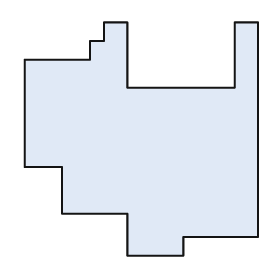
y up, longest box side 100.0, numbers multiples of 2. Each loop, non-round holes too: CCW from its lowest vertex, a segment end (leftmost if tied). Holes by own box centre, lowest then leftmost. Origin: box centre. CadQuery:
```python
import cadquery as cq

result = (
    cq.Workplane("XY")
    .moveTo(-6.0, -50.0)
    .lineTo(18.0, -50.0)
    .lineTo(18.0, -42.0)
    .lineTo(50.0, -42.0)
    .lineTo(50.0, 50.0)
    .lineTo(40.0, 50.0)
    .lineTo(40.0, 22.0)
    .lineTo(-6.0, 22.0)
    .lineTo(-6.0, 50.0)
    .lineTo(-16.0, 50.0)
    .lineTo(-16.0, 42.0)
    .lineTo(-22.0, 42.0)
    .lineTo(-22.0, 34.0)
    .lineTo(-50.0, 34.0)
    .lineTo(-50.0, -12.0)
    .lineTo(-34.0, -12.0)
    .lineTo(-34.0, -32.0)
    .lineTo(-6.0, -32.0)
    .close()
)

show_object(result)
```